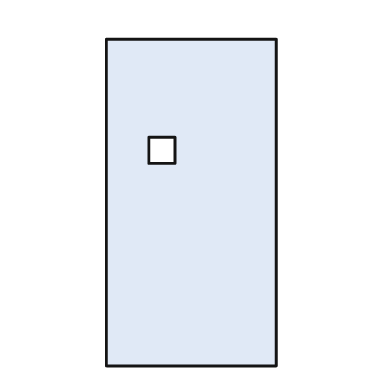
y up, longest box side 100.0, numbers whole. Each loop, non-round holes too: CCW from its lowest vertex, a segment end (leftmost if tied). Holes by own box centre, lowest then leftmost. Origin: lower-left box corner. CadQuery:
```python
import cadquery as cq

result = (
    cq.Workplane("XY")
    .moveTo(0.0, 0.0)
    .lineTo(52.0, 0.0)
    .lineTo(52.0, 100.0)
    .lineTo(0.0, 100.0)
    .close()
    .moveTo(13.0, 62.0)
    .lineTo(21.0, 62.0)
    .lineTo(21.0, 70.0)
    .lineTo(13.0, 70.0)
    .close()
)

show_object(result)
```